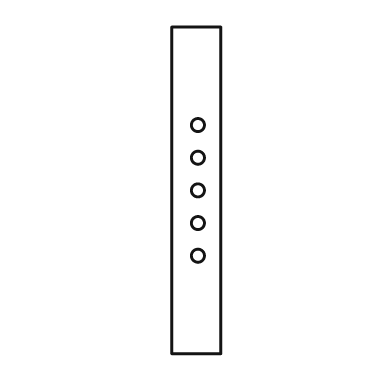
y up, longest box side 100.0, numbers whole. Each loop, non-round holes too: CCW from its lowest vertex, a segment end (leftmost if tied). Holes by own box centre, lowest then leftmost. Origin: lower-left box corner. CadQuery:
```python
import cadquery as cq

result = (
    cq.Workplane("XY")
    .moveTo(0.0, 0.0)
    .lineTo(15.0, 0.0)
    .lineTo(15.0, 100.0)
    .lineTo(0.0, 100.0)
    .close()
    .moveTo(8.0, 30.0)
    .circle(2.0)
    .moveTo(8.0, 40.0)
    .circle(2.0)
    .moveTo(8.0, 50.0)
    .circle(2.0)
    .moveTo(8.0, 60.0)
    .circle(2.0)
    .moveTo(8.0, 70.0)
    .circle(2.0)
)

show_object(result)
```